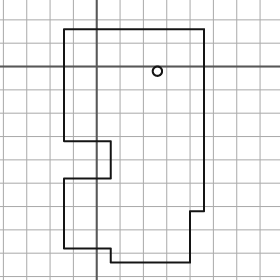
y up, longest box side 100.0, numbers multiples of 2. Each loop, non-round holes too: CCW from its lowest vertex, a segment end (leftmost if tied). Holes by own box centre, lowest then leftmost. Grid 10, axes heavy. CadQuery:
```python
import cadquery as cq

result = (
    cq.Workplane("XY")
    .moveTo(6.0, -84.0)
    .lineTo(40.0, -84.0)
    .lineTo(40.0, -62.0)
    .lineTo(46.0, -62.0)
    .lineTo(46.0, 16.0)
    .lineTo(-14.0, 16.0)
    .lineTo(-14.0, -32.0)
    .lineTo(6.0, -32.0)
    .lineTo(6.0, -48.0)
    .lineTo(-14.0, -48.0)
    .lineTo(-14.0, -78.0)
    .lineTo(6.0, -78.0)
    .close()
    .moveTo(26.0, -2.0)
    .circle(2.0)
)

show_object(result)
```